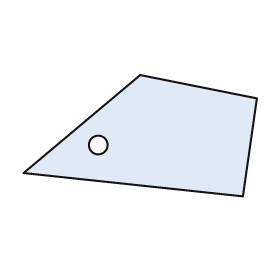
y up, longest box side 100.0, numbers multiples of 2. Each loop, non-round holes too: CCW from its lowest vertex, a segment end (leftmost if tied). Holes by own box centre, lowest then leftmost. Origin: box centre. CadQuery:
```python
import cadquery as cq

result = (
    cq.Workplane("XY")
    .moveTo(44.0, -26.0)
    .lineTo(50.0, 16.0)
    .lineTo(0.0, 26.0)
    .lineTo(-50.0, -16.0)
    .close()
    .moveTo(-18.0, -4.0)
    .circle(4.0)
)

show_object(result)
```